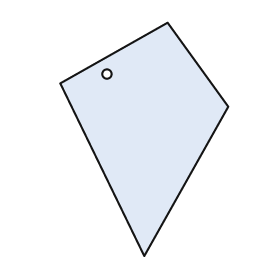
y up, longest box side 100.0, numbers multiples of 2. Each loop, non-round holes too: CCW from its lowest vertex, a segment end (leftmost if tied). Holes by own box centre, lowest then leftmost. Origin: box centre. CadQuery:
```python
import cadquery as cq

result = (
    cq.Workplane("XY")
    .moveTo(0.0, -50.0)
    .lineTo(36.0, 14.0)
    .lineTo(10.0, 50.0)
    .lineTo(-36.0, 24.0)
    .close()
    .moveTo(-16.0, 28.0)
    .circle(2.0)
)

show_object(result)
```